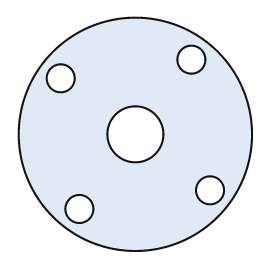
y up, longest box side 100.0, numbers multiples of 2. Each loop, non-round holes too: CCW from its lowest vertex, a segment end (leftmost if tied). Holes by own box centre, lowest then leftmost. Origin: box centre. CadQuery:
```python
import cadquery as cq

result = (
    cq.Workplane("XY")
    .moveTo(0.0, 0.0)
    .circle(50.0)
    .moveTo(-24.0, -32.0)
    .circle(6.0)
    .moveTo(32.0, -24.0)
    .circle(6.0)
    .moveTo(0.0, 0.0)
    .circle(12.0)
    .moveTo(-32.0, 24.0)
    .circle(6.0)
    .moveTo(24.0, 32.0)
    .circle(6.0)
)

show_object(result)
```